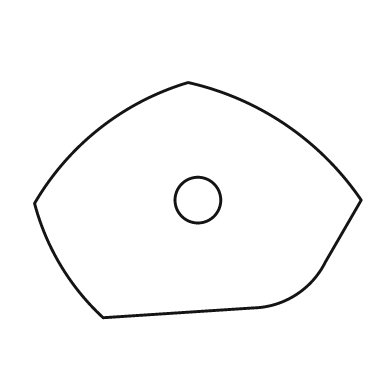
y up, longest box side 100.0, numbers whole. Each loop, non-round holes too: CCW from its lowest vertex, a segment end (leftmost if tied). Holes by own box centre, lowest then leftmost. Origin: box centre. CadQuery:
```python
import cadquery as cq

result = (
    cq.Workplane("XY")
    .moveTo(-29.0, -36.0)
    .lineTo(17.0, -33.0)
    .threePointArc((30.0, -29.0), (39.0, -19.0))
    .lineTo(50.0, 0.0)
    .threePointArc((27.0, 23.0), (-3.0, 36.0))
    .threePointArc((-30.0, 22.0), (-50.0, -1.0))
    .threePointArc((-42.0, -20.0), (-29.0, -36.0))
    .close()
    .moveTo(0.0, 0.0)
    .circle(7.0)
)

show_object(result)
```